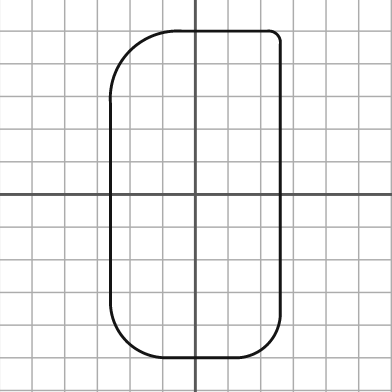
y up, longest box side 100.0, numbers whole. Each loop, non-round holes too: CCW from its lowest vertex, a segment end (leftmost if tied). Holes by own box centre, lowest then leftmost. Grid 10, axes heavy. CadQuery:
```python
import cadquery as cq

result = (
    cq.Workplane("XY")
    .moveTo(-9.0, -50.0)
    .lineTo(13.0, -50.0)
    .threePointArc((22.0, -46.0), (26.0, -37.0))
    .lineTo(26.0, 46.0)
    .threePointArc((25.0, 49.0), (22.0, 50.0))
    .lineTo(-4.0, 50.0)
    .threePointArc((-20.0, 44.0), (-26.0, 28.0))
    .lineTo(-26.0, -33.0)
    .threePointArc((-21.0, -45.0), (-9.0, -50.0))
    .close()
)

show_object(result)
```